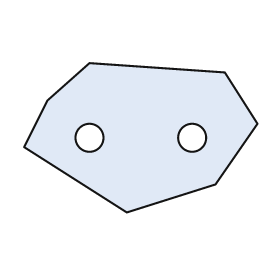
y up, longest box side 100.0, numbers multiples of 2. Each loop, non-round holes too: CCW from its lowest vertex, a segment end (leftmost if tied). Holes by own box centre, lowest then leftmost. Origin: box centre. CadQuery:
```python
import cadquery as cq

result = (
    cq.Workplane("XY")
    .moveTo(-6.0, -32.0)
    .lineTo(32.0, -20.0)
    .lineTo(50.0, 6.0)
    .lineTo(36.0, 28.0)
    .lineTo(-22.0, 32.0)
    .lineTo(-40.0, 16.0)
    .lineTo(-50.0, -4.0)
    .close()
    .moveTo(-22.0, 0.0)
    .circle(6.0)
    .moveTo(22.0, 0.0)
    .circle(6.0)
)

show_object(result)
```